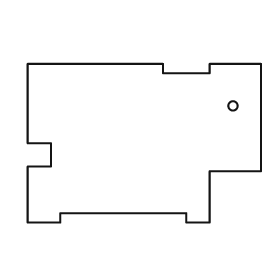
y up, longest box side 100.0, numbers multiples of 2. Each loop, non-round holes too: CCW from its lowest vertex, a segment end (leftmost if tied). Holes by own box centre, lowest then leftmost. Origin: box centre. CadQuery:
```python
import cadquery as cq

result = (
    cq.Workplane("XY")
    .moveTo(-50.0, -34.0)
    .lineTo(-36.0, -34.0)
    .lineTo(-36.0, -30.0)
    .lineTo(18.0, -30.0)
    .lineTo(18.0, -34.0)
    .lineTo(28.0, -34.0)
    .lineTo(28.0, -12.0)
    .lineTo(50.0, -12.0)
    .lineTo(50.0, 34.0)
    .lineTo(28.0, 34.0)
    .lineTo(28.0, 30.0)
    .lineTo(8.0, 30.0)
    .lineTo(8.0, 34.0)
    .lineTo(-50.0, 34.0)
    .lineTo(-50.0, 0.0)
    .lineTo(-40.0, 0.0)
    .lineTo(-40.0, -10.0)
    .lineTo(-50.0, -10.0)
    .close()
    .moveTo(38.0, 16.0)
    .circle(2.0)
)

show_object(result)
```